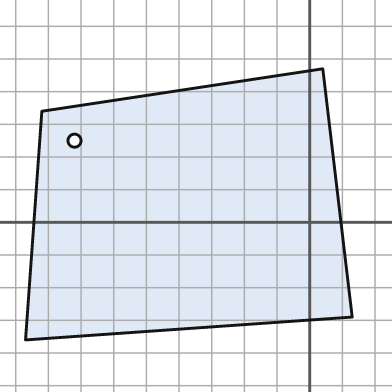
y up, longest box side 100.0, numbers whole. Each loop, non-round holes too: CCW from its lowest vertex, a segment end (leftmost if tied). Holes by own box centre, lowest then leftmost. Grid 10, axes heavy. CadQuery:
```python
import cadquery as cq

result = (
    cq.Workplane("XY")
    .moveTo(-87.0, -36.0)
    .lineTo(13.0, -29.0)
    .lineTo(4.0, 47.0)
    .lineTo(-82.0, 34.0)
    .close()
    .moveTo(-72.0, 25.0)
    .circle(2.0)
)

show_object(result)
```